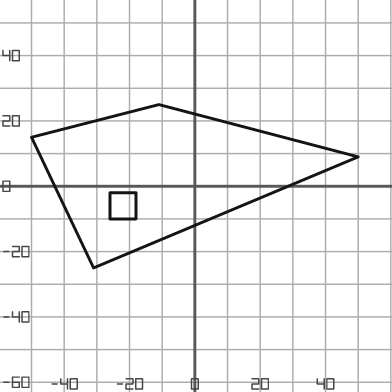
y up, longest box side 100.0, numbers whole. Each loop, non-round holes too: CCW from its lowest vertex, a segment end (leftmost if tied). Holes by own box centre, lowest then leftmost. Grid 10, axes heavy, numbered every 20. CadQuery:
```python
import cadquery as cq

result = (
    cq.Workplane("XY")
    .moveTo(-31.0, -25.0)
    .lineTo(50.0, 9.0)
    .lineTo(-11.0, 25.0)
    .lineTo(-50.0, 15.0)
    .close()
    .moveTo(-26.0, -10.0)
    .lineTo(-18.0, -10.0)
    .lineTo(-18.0, -2.0)
    .lineTo(-26.0, -2.0)
    .close()
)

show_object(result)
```